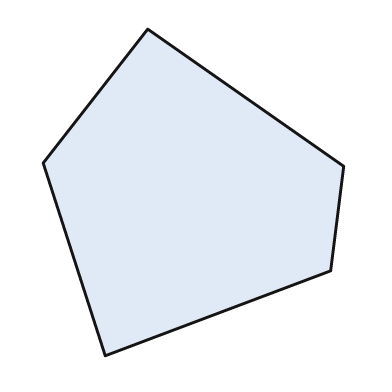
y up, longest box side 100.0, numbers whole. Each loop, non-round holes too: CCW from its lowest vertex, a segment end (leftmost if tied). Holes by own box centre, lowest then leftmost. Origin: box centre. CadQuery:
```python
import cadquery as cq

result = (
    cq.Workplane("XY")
    .moveTo(-27.0, -50.0)
    .lineTo(42.0, -24.0)
    .lineTo(46.0, 8.0)
    .lineTo(-14.0, 50.0)
    .lineTo(-46.0, 9.0)
    .close()
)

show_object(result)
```